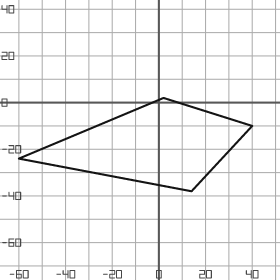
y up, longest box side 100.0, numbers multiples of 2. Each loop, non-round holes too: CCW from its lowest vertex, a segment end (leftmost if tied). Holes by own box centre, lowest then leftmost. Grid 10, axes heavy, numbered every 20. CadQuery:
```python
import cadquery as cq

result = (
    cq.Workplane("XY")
    .moveTo(14.0, -38.0)
    .lineTo(40.0, -10.0)
    .lineTo(2.0, 2.0)
    .lineTo(-60.0, -24.0)
    .close()
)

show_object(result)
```